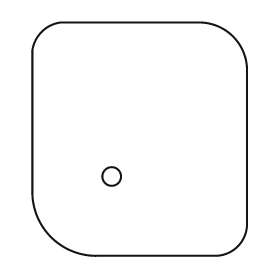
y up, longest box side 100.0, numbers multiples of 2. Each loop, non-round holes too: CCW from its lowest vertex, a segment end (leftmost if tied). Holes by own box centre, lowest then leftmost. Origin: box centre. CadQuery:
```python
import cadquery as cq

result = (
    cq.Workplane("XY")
    .moveTo(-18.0, -50.0)
    .lineTo(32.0, -50.0)
    .threePointArc((42.0, -46.0), (46.0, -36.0))
    .lineTo(46.0, 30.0)
    .threePointArc((40.0, 44.0), (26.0, 50.0))
    .lineTo(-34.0, 50.0)
    .threePointArc((-42.0, 46.0), (-46.0, 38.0))
    .lineTo(-46.0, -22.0)
    .threePointArc((-38.0, -42.0), (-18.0, -50.0))
    .close()
    .moveTo(-12.0, -16.0)
    .circle(4.0)
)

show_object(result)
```